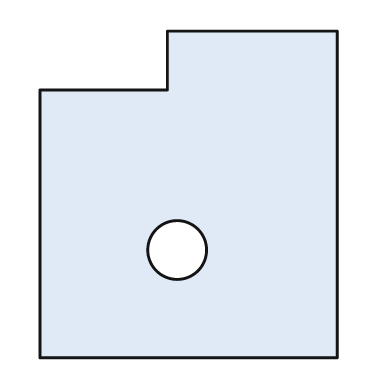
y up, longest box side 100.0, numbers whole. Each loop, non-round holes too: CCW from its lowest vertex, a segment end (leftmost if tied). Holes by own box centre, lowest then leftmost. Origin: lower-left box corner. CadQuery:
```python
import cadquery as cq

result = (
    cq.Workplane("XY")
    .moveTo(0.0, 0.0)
    .lineTo(91.0, 0.0)
    .lineTo(91.0, 100.0)
    .lineTo(39.0, 100.0)
    .lineTo(39.0, 82.0)
    .lineTo(0.0, 82.0)
    .close()
    .moveTo(42.0, 33.0)
    .circle(9.0)
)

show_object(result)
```